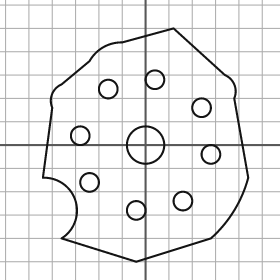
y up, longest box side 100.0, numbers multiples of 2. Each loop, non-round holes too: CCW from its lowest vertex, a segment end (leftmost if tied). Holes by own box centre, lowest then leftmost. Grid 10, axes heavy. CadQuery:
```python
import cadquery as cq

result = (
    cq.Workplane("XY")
    .moveTo(-4.0, -50.0)
    .lineTo(28.0, -40.0)
    .threePointArc((38.0, -28.0), (44.0, -14.0))
    .lineTo(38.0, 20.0)
    .threePointArc((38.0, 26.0), (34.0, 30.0))
    .lineTo(12.0, 50.0)
    .lineTo(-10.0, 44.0)
    .threePointArc((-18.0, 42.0), (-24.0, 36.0))
    .lineTo(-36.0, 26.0)
    .threePointArc((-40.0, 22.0), (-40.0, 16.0))
    .lineTo(-44.0, -14.0)
    .threePointArc((-30.0, -24.0), (-36.0, -40.0))
    .close()
    .moveTo(-4.0, -28.0)
    .circle(4.0)
    .moveTo(16.0, -24.0)
    .circle(4.0)
    .moveTo(-24.0, -16.0)
    .circle(4.0)
    .moveTo(28.0, -4.0)
    .circle(4.0)
    .moveTo(0.0, 0.0)
    .circle(8.0)
    .moveTo(-28.0, 4.0)
    .circle(4.0)
    .moveTo(24.0, 16.0)
    .circle(4.0)
    .moveTo(-16.0, 24.0)
    .circle(4.0)
    .moveTo(4.0, 28.0)
    .circle(4.0)
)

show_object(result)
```